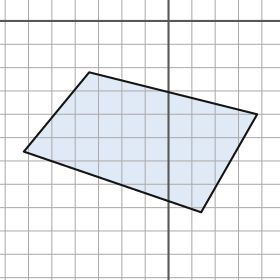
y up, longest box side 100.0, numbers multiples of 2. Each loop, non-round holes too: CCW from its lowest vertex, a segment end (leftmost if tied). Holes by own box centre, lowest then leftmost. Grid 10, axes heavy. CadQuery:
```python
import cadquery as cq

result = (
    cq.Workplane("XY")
    .moveTo(14.0, -82.0)
    .lineTo(38.0, -40.0)
    .lineTo(-34.0, -22.0)
    .lineTo(-62.0, -56.0)
    .close()
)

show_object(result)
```